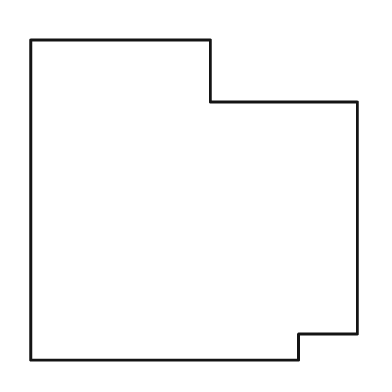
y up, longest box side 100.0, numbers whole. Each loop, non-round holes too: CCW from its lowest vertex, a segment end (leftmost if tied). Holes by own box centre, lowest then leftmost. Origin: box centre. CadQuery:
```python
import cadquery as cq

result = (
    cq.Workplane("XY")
    .moveTo(-50.0, -49.0)
    .lineTo(32.0, -49.0)
    .lineTo(32.0, -41.0)
    .lineTo(50.0, -41.0)
    .lineTo(50.0, 30.0)
    .lineTo(5.0, 30.0)
    .lineTo(5.0, 49.0)
    .lineTo(-50.0, 49.0)
    .close()
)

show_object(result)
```